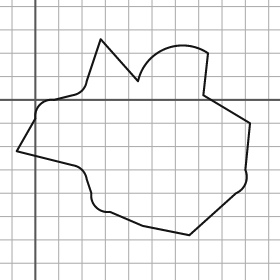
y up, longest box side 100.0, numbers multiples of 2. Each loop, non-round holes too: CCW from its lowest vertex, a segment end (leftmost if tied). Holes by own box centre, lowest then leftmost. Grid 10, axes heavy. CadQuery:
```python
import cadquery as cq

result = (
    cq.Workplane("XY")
    .moveTo(66.0, -58.0)
    .lineTo(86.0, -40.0)
    .threePointArc((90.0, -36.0), (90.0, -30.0))
    .lineTo(92.0, -10.0)
    .lineTo(72.0, 2.0)
    .lineTo(74.0, 20.0)
    .threePointArc((56.0, 22.0), (44.0, 8.0))
    .lineTo(28.0, 26.0)
    .lineTo(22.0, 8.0)
    .threePointArc((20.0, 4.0), (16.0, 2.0))
    .lineTo(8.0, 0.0)
    .threePointArc((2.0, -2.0), (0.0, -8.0))
    .lineTo(-8.0, -22.0)
    .lineTo(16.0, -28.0)
    .threePointArc((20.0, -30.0), (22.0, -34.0))
    .lineTo(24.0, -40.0)
    .threePointArc((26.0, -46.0), (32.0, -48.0))
    .lineTo(46.0, -54.0)
    .close()
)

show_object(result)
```